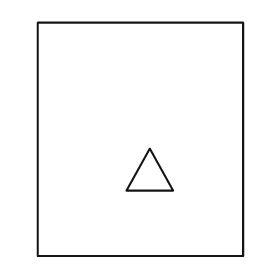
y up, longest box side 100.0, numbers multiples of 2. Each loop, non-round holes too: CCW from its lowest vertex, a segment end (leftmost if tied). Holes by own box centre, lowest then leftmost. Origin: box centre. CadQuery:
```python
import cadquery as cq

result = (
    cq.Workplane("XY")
    .moveTo(-44.0, -50.0)
    .lineTo(44.0, -50.0)
    .lineTo(44.0, 50.0)
    .lineTo(-44.0, 50.0)
    .close()
    .moveTo(-6.0, -22.0)
    .lineTo(14.0, -22.0)
    .lineTo(4.0, -4.0)
    .close()
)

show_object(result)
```